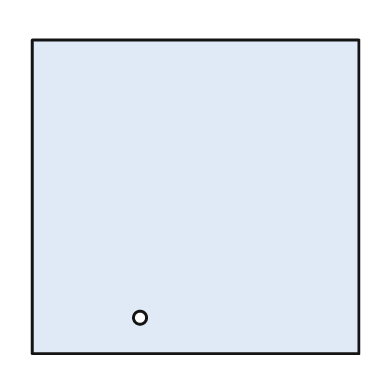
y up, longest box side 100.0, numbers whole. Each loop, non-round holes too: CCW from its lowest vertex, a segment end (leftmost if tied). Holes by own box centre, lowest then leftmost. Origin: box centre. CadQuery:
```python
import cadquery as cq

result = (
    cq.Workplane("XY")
    .moveTo(-50.0, -48.0)
    .lineTo(50.0, -48.0)
    .lineTo(50.0, 48.0)
    .lineTo(-50.0, 48.0)
    .close()
    .moveTo(-17.0, -37.0)
    .circle(2.0)
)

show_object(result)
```